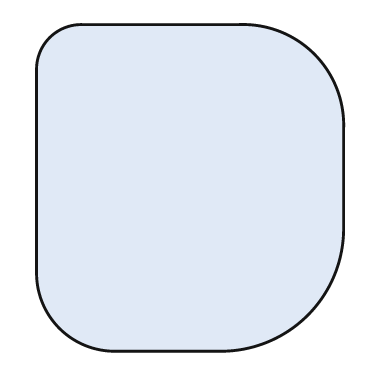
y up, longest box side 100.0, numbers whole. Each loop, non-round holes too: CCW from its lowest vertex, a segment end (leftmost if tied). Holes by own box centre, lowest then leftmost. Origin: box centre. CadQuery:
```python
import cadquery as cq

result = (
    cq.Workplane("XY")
    .moveTo(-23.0, -50.0)
    .lineTo(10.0, -50.0)
    .threePointArc((36.0, -39.0), (47.0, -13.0))
    .lineTo(47.0, 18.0)
    .threePointArc((38.0, 41.0), (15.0, 50.0))
    .lineTo(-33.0, 50.0)
    .threePointArc((-43.0, 46.0), (-47.0, 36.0))
    .lineTo(-47.0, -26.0)
    .threePointArc((-40.0, -43.0), (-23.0, -50.0))
    .close()
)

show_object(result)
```